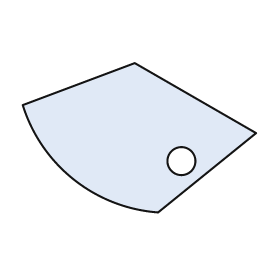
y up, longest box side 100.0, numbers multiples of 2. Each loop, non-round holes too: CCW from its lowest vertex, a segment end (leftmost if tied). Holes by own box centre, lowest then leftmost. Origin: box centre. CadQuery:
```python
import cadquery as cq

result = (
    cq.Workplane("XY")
    .moveTo(8.0, -32.0)
    .lineTo(50.0, 2.0)
    .lineTo(-2.0, 32.0)
    .lineTo(-50.0, 14.0)
    .threePointArc((-28.0, -18.0), (8.0, -32.0))
    .close()
    .moveTo(18.0, -10.0)
    .circle(6.0)
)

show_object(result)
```